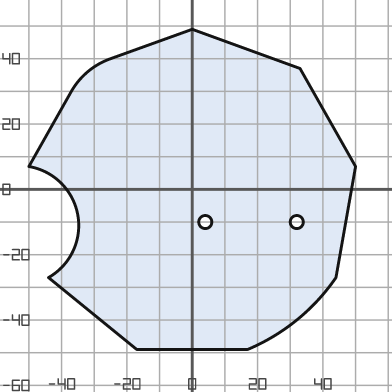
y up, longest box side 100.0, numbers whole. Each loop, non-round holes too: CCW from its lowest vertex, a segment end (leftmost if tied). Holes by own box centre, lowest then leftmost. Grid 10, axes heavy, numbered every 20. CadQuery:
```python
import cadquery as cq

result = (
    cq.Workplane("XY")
    .moveTo(-17.0, -49.0)
    .lineTo(17.0, -49.0)
    .threePointArc((32.0, -40.0), (44.0, -27.0))
    .lineTo(50.0, 7.0)
    .lineTo(33.0, 37.0)
    .lineTo(0.0, 49.0)
    .lineTo(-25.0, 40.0)
    .threePointArc((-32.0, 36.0), (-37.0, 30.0))
    .lineTo(-50.0, 7.0)
    .threePointArc((-35.0, -8.0), (-44.0, -27.0))
    .close()
    .moveTo(4.0, -10.0)
    .circle(2.0)
    .moveTo(32.0, -10.0)
    .circle(2.0)
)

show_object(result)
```